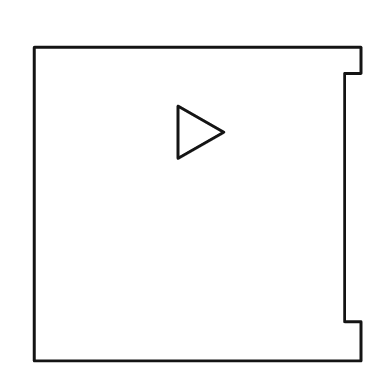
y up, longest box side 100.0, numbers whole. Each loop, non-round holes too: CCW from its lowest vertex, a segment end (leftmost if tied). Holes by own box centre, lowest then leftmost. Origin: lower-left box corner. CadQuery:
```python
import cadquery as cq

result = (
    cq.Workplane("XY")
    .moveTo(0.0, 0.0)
    .lineTo(100.0, 0.0)
    .lineTo(100.0, 12.0)
    .lineTo(95.0, 12.0)
    .lineTo(95.0, 88.0)
    .lineTo(100.0, 88.0)
    .lineTo(100.0, 96.0)
    .lineTo(0.0, 96.0)
    .close()
    .moveTo(44.0, 62.0)
    .lineTo(58.0, 70.0)
    .lineTo(44.0, 78.0)
    .close()
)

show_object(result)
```